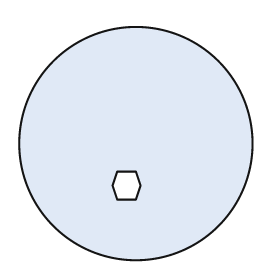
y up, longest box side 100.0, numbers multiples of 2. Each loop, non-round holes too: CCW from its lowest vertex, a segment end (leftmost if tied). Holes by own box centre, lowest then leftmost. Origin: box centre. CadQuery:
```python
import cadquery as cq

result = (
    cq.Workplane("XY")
    .moveTo(0.0, 0.0)
    .circle(50.0)
    .moveTo(-8.0, -24.0)
    .lineTo(0.0, -24.0)
    .lineTo(2.0, -18.0)
    .lineTo(0.0, -12.0)
    .lineTo(-8.0, -12.0)
    .lineTo(-10.0, -18.0)
    .close()
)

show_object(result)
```